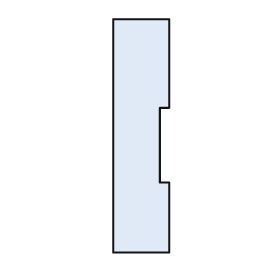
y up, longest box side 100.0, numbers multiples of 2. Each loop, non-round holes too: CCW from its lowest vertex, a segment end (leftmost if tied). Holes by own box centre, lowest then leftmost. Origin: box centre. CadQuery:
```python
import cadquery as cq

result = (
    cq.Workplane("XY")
    .moveTo(-12.0, -50.0)
    .lineTo(12.0, -50.0)
    .lineTo(12.0, -20.0)
    .lineTo(8.0, -20.0)
    .lineTo(8.0, 12.0)
    .lineTo(12.0, 12.0)
    .lineTo(12.0, 50.0)
    .lineTo(-12.0, 50.0)
    .close()
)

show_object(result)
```